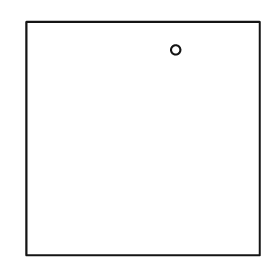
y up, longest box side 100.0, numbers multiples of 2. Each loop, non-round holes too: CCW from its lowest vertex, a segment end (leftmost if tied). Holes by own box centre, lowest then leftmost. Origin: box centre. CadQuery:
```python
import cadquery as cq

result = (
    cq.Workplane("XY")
    .moveTo(-50.0, -50.0)
    .lineTo(50.0, -50.0)
    .lineTo(50.0, 50.0)
    .lineTo(-50.0, 50.0)
    .close()
    .moveTo(14.0, 38.0)
    .circle(2.0)
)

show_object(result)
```